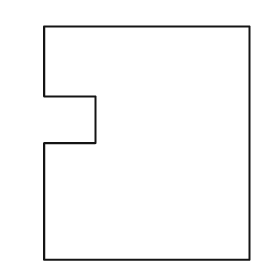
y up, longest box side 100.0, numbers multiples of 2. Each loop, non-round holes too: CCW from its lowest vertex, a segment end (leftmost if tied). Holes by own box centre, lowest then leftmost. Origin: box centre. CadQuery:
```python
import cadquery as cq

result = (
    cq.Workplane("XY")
    .moveTo(-44.0, -50.0)
    .lineTo(44.0, -50.0)
    .lineTo(44.0, 50.0)
    .lineTo(-44.0, 50.0)
    .lineTo(-44.0, 20.0)
    .lineTo(-22.0, 20.0)
    .lineTo(-22.0, 0.0)
    .lineTo(-44.0, 0.0)
    .close()
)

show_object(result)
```